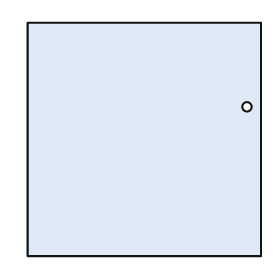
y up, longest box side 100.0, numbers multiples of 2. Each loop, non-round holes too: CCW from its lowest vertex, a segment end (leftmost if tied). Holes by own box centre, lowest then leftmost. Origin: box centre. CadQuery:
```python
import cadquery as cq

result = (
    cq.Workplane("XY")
    .moveTo(-50.0, -50.0)
    .lineTo(50.0, -50.0)
    .lineTo(50.0, 50.0)
    .lineTo(-50.0, 50.0)
    .close()
    .moveTo(44.0, 14.0)
    .circle(2.0)
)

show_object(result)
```